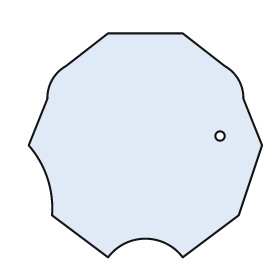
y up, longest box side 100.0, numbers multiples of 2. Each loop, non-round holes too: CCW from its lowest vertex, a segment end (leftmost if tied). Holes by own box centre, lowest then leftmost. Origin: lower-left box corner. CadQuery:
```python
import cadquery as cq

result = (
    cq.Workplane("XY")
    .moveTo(34.0, 0.0)
    .threePointArc((50.0, 8.0), (66.0, 0.0))
    .lineTo(90.0, 18.0)
    .lineTo(100.0, 48.0)
    .lineTo(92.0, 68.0)
    .threePointArc((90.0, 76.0), (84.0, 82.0))
    .lineTo(66.0, 96.0)
    .lineTo(34.0, 96.0)
    .lineTo(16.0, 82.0)
    .threePointArc((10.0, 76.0), (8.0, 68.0))
    .lineTo(0.0, 48.0)
    .threePointArc((8.0, 34.0), (10.0, 18.0))
    .close()
    .moveTo(82.0, 52.0)
    .circle(2.0)
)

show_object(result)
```